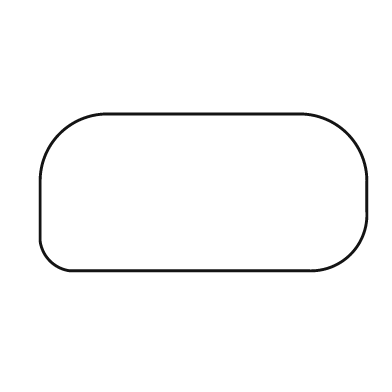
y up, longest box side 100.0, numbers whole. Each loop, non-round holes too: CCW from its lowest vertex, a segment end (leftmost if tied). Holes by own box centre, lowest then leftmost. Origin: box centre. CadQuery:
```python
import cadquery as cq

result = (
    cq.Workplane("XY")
    .moveTo(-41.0, -24.0)
    .lineTo(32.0, -24.0)
    .threePointArc((45.0, -19.0), (50.0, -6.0))
    .lineTo(50.0, 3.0)
    .threePointArc((44.0, 18.0), (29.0, 24.0))
    .lineTo(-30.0, 24.0)
    .threePointArc((-44.0, 18.0), (-50.0, 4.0))
    .lineTo(-50.0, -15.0)
    .threePointArc((-47.0, -21.0), (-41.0, -24.0))
    .close()
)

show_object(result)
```